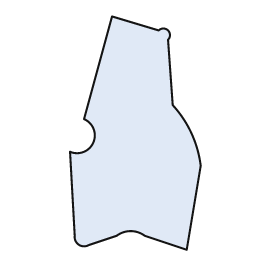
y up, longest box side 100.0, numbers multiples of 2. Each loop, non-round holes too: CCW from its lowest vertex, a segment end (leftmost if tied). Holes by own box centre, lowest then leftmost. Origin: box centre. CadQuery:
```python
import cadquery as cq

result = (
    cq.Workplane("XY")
    .moveTo(22.0, -50.0)
    .lineTo(28.0, -14.0)
    .threePointArc((24.0, 0.0), (16.0, 12.0))
    .lineTo(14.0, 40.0)
    .threePointArc((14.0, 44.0), (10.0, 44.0))
    .lineTo(-10.0, 50.0)
    .lineTo(-22.0, 6.0)
    .threePointArc((-18.0, -4.0), (-28.0, -8.0))
    .lineTo(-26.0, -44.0)
    .threePointArc((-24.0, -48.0), (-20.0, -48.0))
    .lineTo(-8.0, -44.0)
    .threePointArc((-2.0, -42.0), (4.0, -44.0))
    .close()
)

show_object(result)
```